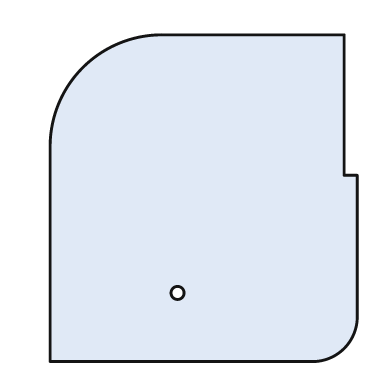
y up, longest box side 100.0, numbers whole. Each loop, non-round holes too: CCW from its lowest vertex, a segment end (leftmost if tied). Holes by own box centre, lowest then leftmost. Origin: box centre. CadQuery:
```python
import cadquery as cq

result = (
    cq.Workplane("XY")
    .moveTo(-47.0, -50.0)
    .lineTo(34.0, -50.0)
    .threePointArc((43.0, -46.0), (47.0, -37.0))
    .lineTo(47.0, 7.0)
    .lineTo(43.0, 7.0)
    .lineTo(43.0, 50.0)
    .lineTo(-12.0, 50.0)
    .threePointArc((-37.0, 40.0), (-47.0, 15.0))
    .close()
    .moveTo(-8.0, -29.0)
    .circle(2.0)
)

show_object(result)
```